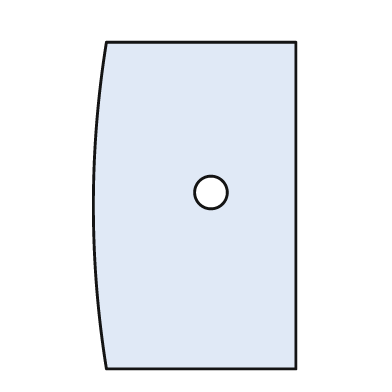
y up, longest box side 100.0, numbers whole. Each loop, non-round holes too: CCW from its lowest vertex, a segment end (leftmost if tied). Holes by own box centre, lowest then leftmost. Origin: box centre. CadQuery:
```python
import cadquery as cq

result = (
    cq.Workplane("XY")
    .moveTo(-27.0, -50.0)
    .lineTo(31.0, -50.0)
    .lineTo(31.0, 50.0)
    .lineTo(-27.0, 50.0)
    .threePointArc((-31.0, 0.0), (-27.0, -50.0))
    .close()
    .moveTo(5.0, 4.0)
    .circle(5.0)
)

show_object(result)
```